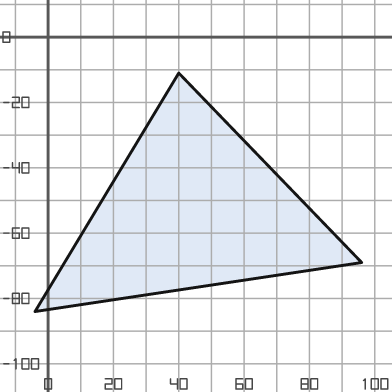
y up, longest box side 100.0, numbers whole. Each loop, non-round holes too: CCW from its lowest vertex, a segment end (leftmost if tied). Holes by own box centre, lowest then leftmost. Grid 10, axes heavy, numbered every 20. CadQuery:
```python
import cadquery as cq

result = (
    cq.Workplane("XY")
    .moveTo(-4.0, -84.0)
    .lineTo(96.0, -69.0)
    .lineTo(40.0, -11.0)
    .close()
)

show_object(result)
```